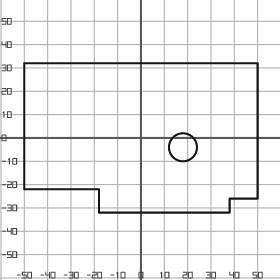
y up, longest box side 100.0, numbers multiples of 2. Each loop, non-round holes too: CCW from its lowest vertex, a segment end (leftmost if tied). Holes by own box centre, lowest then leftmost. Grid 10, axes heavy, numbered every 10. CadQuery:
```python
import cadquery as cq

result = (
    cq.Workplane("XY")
    .moveTo(-18.0, -32.0)
    .lineTo(38.0, -32.0)
    .lineTo(38.0, -26.0)
    .lineTo(50.0, -26.0)
    .lineTo(50.0, 32.0)
    .lineTo(-50.0, 32.0)
    .lineTo(-50.0, -22.0)
    .lineTo(-18.0, -22.0)
    .close()
    .moveTo(18.0, -4.0)
    .circle(6.0)
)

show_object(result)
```